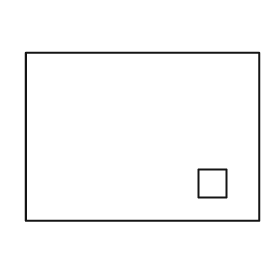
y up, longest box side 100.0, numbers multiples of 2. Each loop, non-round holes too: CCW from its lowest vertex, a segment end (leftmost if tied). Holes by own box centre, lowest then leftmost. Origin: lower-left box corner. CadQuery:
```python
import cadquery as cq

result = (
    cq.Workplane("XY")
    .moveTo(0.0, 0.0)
    .lineTo(100.0, 0.0)
    .lineTo(100.0, 72.0)
    .lineTo(0.0, 72.0)
    .close()
    .moveTo(74.0, 10.0)
    .lineTo(86.0, 10.0)
    .lineTo(86.0, 22.0)
    .lineTo(74.0, 22.0)
    .close()
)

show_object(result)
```